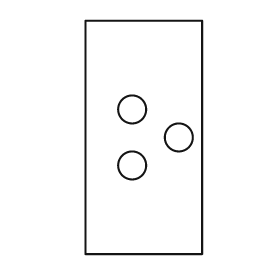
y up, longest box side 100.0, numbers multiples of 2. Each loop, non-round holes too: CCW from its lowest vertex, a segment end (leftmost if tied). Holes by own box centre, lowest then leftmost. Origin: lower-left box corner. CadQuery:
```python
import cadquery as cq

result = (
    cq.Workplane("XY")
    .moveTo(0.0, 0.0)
    .lineTo(50.0, 0.0)
    .lineTo(50.0, 100.0)
    .lineTo(0.0, 100.0)
    .close()
    .moveTo(20.0, 38.0)
    .circle(6.0)
    .moveTo(40.0, 50.0)
    .circle(6.0)
    .moveTo(20.0, 62.0)
    .circle(6.0)
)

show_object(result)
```